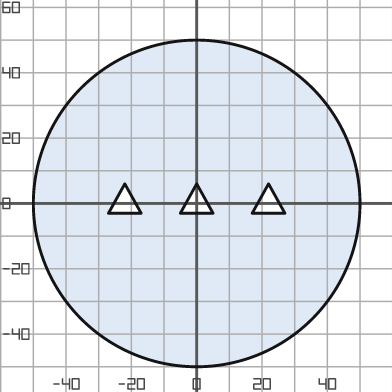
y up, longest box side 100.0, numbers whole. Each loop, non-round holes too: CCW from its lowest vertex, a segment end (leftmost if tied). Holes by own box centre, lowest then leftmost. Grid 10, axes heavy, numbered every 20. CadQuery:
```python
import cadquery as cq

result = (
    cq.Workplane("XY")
    .moveTo(0.0, 0.0)
    .circle(50.0)
    .moveTo(-27.0, -3.0)
    .lineTo(-17.0, -3.0)
    .lineTo(-22.0, 6.0)
    .close()
    .moveTo(-5.0, -3.0)
    .lineTo(5.0, -3.0)
    .lineTo(0.0, 6.0)
    .close()
    .moveTo(17.0, -3.0)
    .lineTo(27.0, -3.0)
    .lineTo(22.0, 6.0)
    .close()
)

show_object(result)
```